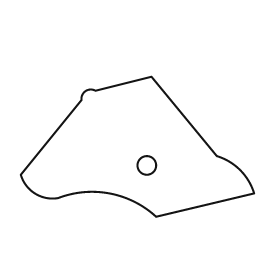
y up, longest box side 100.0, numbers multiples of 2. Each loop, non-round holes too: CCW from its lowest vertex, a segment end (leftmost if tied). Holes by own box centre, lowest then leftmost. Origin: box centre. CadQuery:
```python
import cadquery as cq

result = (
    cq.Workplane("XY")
    .moveTo(8.0, -30.0)
    .lineTo(50.0, -20.0)
    .threePointArc((44.0, -10.0), (34.0, -4.0))
    .lineTo(6.0, 30.0)
    .lineTo(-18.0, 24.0)
    .threePointArc((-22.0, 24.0), (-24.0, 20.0))
    .lineTo(-50.0, -12.0)
    .threePointArc((-44.0, -20.0), (-34.0, -22.0))
    .threePointArc((-12.0, -20.0), (8.0, -30.0))
    .close()
    .moveTo(4.0, -8.0)
    .circle(4.0)
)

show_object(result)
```